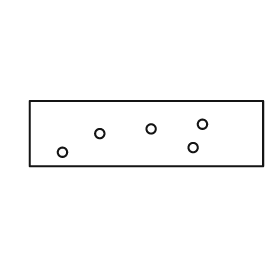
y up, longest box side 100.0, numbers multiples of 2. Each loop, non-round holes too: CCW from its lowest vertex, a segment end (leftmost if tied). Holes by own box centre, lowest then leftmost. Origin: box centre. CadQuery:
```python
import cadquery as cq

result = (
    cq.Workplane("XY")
    .moveTo(-50.0, -14.0)
    .lineTo(50.0, -14.0)
    .lineTo(50.0, 14.0)
    .lineTo(-50.0, 14.0)
    .close()
    .moveTo(-36.0, -8.0)
    .circle(2.0)
    .moveTo(20.0, -6.0)
    .circle(2.0)
    .moveTo(-20.0, 0.0)
    .circle(2.0)
    .moveTo(2.0, 2.0)
    .circle(2.0)
    .moveTo(24.0, 4.0)
    .circle(2.0)
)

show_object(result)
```